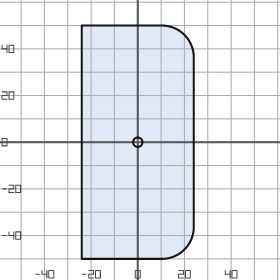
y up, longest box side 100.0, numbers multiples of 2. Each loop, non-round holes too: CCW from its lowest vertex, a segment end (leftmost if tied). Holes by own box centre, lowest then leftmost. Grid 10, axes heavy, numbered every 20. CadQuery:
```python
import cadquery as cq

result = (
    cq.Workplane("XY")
    .moveTo(-24.0, -50.0)
    .lineTo(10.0, -50.0)
    .threePointArc((20.0, -46.0), (24.0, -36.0))
    .lineTo(24.0, 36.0)
    .threePointArc((20.0, 46.0), (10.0, 50.0))
    .lineTo(-24.0, 50.0)
    .close()
    .moveTo(0.0, 0.0)
    .circle(2.0)
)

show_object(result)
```